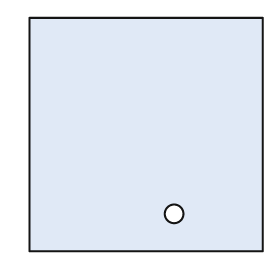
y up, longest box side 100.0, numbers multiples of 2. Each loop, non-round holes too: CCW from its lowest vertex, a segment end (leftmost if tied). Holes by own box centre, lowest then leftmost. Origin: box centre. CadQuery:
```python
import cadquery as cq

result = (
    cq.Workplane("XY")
    .moveTo(-50.0, -50.0)
    .lineTo(50.0, -50.0)
    .lineTo(50.0, 50.0)
    .lineTo(-50.0, 50.0)
    .close()
    .moveTo(12.0, -34.0)
    .circle(4.0)
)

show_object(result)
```